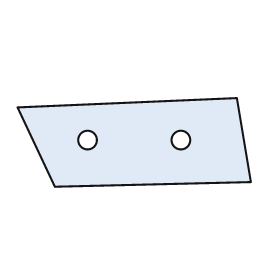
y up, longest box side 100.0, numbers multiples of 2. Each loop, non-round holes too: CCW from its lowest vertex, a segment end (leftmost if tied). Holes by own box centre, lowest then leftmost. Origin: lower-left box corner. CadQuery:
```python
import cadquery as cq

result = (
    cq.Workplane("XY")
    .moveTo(16.0, 0.0)
    .lineTo(100.0, 2.0)
    .lineTo(94.0, 38.0)
    .lineTo(0.0, 34.0)
    .close()
    .moveTo(30.0, 20.0)
    .circle(4.0)
    .moveTo(70.0, 20.0)
    .circle(4.0)
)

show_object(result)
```